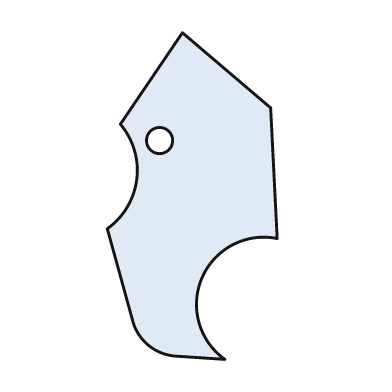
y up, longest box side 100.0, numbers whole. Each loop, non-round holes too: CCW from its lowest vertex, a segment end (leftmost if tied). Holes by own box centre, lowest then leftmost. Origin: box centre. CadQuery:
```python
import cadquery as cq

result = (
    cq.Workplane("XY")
    .moveTo(10.0, -50.0)
    .threePointArc((3.0, -25.0), (26.0, -13.0))
    .lineTo(24.0, 27.0)
    .lineTo(-3.0, 50.0)
    .lineTo(-22.0, 22.0)
    .threePointArc((-17.0, 5.0), (-26.0, -10.0))
    .lineTo(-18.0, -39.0)
    .threePointArc((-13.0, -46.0), (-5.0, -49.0))
    .close()
    .moveTo(-10.0, 17.0)
    .circle(4.0)
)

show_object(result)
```